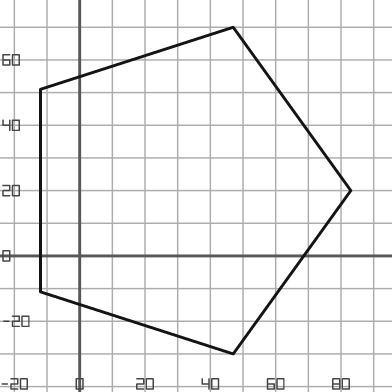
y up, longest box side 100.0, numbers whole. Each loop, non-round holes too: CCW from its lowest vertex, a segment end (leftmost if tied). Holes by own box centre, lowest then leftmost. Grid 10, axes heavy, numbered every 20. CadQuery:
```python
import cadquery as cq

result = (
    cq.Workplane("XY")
    .moveTo(47.0, -30.0)
    .lineTo(83.0, 20.0)
    .lineTo(47.0, 70.0)
    .lineTo(-12.0, 51.0)
    .lineTo(-12.0, -11.0)
    .close()
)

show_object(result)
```